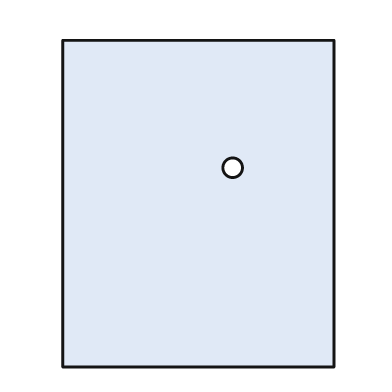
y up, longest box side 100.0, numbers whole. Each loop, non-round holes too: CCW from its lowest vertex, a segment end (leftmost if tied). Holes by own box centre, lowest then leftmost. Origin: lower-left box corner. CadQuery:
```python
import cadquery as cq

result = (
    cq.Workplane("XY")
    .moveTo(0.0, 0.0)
    .lineTo(83.0, 0.0)
    .lineTo(83.0, 100.0)
    .lineTo(0.0, 100.0)
    .close()
    .moveTo(52.0, 61.0)
    .circle(3.0)
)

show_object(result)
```